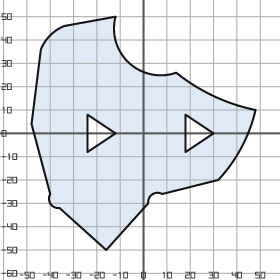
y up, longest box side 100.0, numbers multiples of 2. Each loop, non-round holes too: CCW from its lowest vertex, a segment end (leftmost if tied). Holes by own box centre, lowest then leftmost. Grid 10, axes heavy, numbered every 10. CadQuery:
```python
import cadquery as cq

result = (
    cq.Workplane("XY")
    .moveTo(-16.0, -50.0)
    .lineTo(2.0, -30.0)
    .threePointArc((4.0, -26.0), (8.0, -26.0))
    .lineTo(32.0, -20.0)
    .threePointArc((42.0, -6.0), (48.0, 10.0))
    .threePointArc((30.0, 16.0), (14.0, 26.0))
    .threePointArc((-6.0, 30.0), (-12.0, 50.0))
    .lineTo(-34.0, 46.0)
    .threePointArc((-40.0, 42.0), (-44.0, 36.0))
    .lineTo(-48.0, 4.0)
    .lineTo(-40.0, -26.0)
    .threePointArc((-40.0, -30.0), (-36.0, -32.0))
    .close()
    .moveTo(-24.0, -8.0)
    .lineTo(-12.0, 0.0)
    .lineTo(-24.0, 8.0)
    .close()
    .moveTo(18.0, -8.0)
    .lineTo(30.0, 0.0)
    .lineTo(18.0, 8.0)
    .close()
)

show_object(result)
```